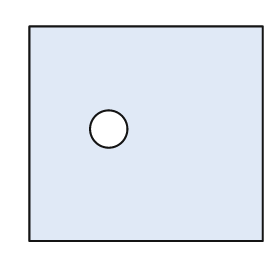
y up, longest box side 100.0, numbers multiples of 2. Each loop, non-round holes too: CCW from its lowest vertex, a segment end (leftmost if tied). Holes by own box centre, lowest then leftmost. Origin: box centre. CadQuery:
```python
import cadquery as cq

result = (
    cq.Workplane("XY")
    .moveTo(-50.0, -46.0)
    .lineTo(50.0, -46.0)
    .lineTo(50.0, 46.0)
    .lineTo(-50.0, 46.0)
    .close()
    .moveTo(-16.0, 2.0)
    .circle(8.0)
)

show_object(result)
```